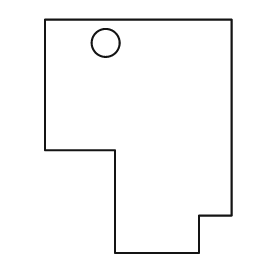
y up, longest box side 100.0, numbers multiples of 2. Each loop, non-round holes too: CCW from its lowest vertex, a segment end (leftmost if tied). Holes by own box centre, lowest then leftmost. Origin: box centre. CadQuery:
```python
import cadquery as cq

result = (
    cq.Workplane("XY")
    .moveTo(-10.0, -50.0)
    .lineTo(26.0, -50.0)
    .lineTo(26.0, -34.0)
    .lineTo(40.0, -34.0)
    .lineTo(40.0, 50.0)
    .lineTo(-40.0, 50.0)
    .lineTo(-40.0, -6.0)
    .lineTo(-10.0, -6.0)
    .close()
    .moveTo(-14.0, 40.0)
    .circle(6.0)
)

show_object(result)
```